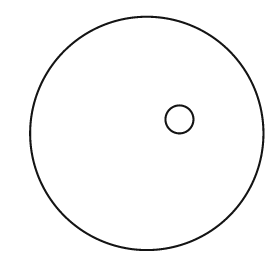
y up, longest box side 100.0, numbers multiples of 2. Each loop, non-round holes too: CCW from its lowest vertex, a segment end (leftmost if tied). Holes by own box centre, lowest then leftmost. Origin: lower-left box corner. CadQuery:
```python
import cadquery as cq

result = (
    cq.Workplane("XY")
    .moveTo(50.0, 50.0)
    .circle(50.0)
    .moveTo(64.0, 56.0)
    .circle(6.0)
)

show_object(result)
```